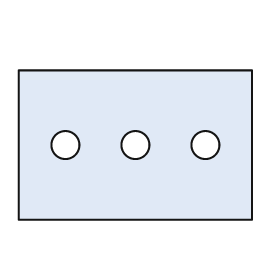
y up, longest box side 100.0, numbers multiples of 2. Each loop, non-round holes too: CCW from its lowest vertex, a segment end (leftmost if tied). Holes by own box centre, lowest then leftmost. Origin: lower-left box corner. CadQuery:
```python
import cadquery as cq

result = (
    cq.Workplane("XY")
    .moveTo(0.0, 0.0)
    .lineTo(100.0, 0.0)
    .lineTo(100.0, 64.0)
    .lineTo(0.0, 64.0)
    .close()
    .moveTo(20.0, 32.0)
    .circle(6.0)
    .moveTo(50.0, 32.0)
    .circle(6.0)
    .moveTo(80.0, 32.0)
    .circle(6.0)
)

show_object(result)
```